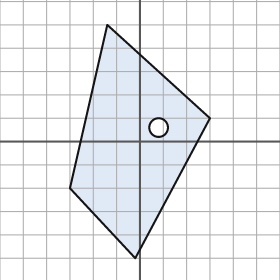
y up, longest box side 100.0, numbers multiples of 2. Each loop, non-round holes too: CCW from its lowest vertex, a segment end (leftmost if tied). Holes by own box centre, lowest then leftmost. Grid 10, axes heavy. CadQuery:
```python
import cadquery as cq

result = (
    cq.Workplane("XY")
    .moveTo(-2.0, -50.0)
    .lineTo(30.0, 10.0)
    .lineTo(-14.0, 50.0)
    .lineTo(-30.0, -20.0)
    .close()
    .moveTo(8.0, 6.0)
    .circle(4.0)
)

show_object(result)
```